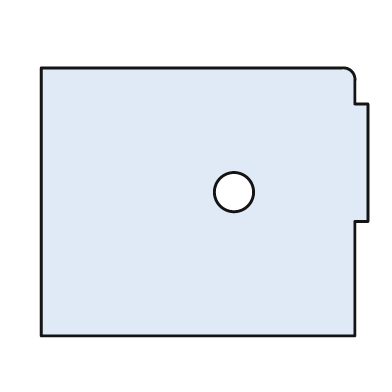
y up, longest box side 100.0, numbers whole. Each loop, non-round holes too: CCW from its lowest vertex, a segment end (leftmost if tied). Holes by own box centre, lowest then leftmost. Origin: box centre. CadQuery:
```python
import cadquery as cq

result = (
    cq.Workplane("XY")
    .moveTo(-50.0, -41.0)
    .lineTo(46.0, -41.0)
    .lineTo(46.0, -6.0)
    .lineTo(50.0, -6.0)
    .lineTo(50.0, 30.0)
    .lineTo(46.0, 30.0)
    .lineTo(46.0, 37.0)
    .threePointArc((45.0, 40.0), (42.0, 41.0))
    .lineTo(-50.0, 41.0)
    .close()
    .moveTo(9.0, 3.0)
    .circle(6.0)
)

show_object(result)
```